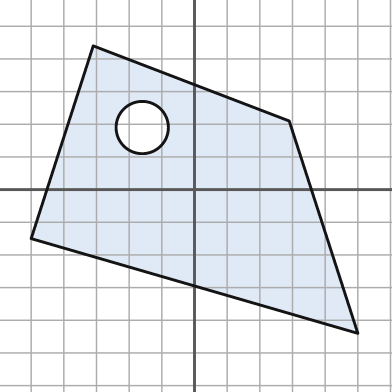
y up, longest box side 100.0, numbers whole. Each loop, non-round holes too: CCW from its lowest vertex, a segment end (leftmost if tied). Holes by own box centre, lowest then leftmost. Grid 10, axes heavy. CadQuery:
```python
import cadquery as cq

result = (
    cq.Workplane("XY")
    .moveTo(50.0, -44.0)
    .lineTo(29.0, 21.0)
    .lineTo(-31.0, 44.0)
    .lineTo(-50.0, -15.0)
    .close()
    .moveTo(-16.0, 19.0)
    .circle(8.0)
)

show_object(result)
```